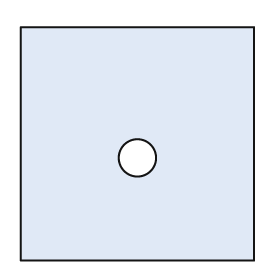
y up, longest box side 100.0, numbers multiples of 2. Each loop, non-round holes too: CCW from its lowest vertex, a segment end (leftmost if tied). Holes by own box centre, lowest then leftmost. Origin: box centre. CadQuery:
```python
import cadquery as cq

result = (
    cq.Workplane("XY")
    .moveTo(-50.0, -50.0)
    .lineTo(50.0, -50.0)
    .lineTo(50.0, 50.0)
    .lineTo(-50.0, 50.0)
    .close()
    .moveTo(0.0, -6.0)
    .circle(8.0)
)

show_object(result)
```